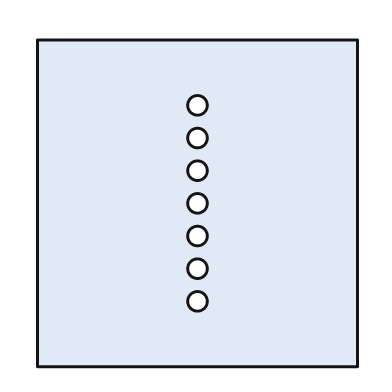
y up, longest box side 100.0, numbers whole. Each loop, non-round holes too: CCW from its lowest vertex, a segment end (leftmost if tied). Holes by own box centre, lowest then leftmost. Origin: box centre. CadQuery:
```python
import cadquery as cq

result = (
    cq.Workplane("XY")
    .moveTo(-49.0, -50.0)
    .lineTo(49.0, -50.0)
    .lineTo(49.0, 50.0)
    .lineTo(-49.0, 50.0)
    .close()
    .moveTo(0.0, -30.0)
    .circle(3.0)
    .moveTo(0.0, -20.0)
    .circle(3.0)
    .moveTo(0.0, -10.0)
    .circle(3.0)
    .moveTo(0.0, 0.0)
    .circle(3.0)
    .moveTo(0.0, 10.0)
    .circle(3.0)
    .moveTo(0.0, 20.0)
    .circle(3.0)
    .moveTo(0.0, 30.0)
    .circle(3.0)
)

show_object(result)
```